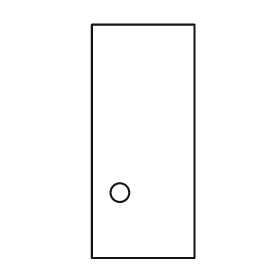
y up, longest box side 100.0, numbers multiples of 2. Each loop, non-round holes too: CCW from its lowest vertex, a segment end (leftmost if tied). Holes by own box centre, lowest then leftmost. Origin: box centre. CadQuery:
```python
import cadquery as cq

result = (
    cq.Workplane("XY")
    .moveTo(-22.0, -50.0)
    .lineTo(22.0, -50.0)
    .lineTo(22.0, 50.0)
    .lineTo(-22.0, 50.0)
    .close()
    .moveTo(-10.0, -22.0)
    .circle(4.0)
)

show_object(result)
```